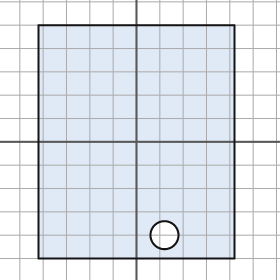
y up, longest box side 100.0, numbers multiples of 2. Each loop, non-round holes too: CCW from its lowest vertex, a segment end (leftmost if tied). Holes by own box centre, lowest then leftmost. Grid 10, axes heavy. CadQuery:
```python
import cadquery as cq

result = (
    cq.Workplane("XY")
    .moveTo(-42.0, -50.0)
    .lineTo(42.0, -50.0)
    .lineTo(42.0, 50.0)
    .lineTo(-42.0, 50.0)
    .close()
    .moveTo(12.0, -40.0)
    .circle(6.0)
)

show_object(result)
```